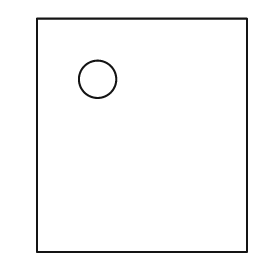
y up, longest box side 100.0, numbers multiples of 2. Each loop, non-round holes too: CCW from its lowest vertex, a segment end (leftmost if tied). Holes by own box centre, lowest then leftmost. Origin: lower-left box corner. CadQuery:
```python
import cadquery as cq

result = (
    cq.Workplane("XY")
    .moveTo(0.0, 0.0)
    .lineTo(90.0, 0.0)
    .lineTo(90.0, 100.0)
    .lineTo(0.0, 100.0)
    .close()
    .moveTo(26.0, 74.0)
    .circle(8.0)
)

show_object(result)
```